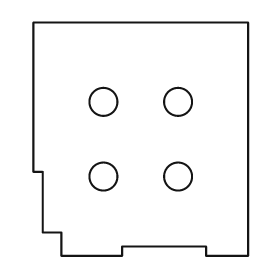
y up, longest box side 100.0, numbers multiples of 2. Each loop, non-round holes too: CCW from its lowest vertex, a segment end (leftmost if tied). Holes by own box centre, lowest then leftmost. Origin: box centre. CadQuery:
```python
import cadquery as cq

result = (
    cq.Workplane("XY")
    .moveTo(-34.0, -50.0)
    .lineTo(-8.0, -50.0)
    .lineTo(-8.0, -46.0)
    .lineTo(28.0, -46.0)
    .lineTo(28.0, -50.0)
    .lineTo(46.0, -50.0)
    .lineTo(46.0, 50.0)
    .lineTo(-46.0, 50.0)
    .lineTo(-46.0, -14.0)
    .lineTo(-42.0, -14.0)
    .lineTo(-42.0, -40.0)
    .lineTo(-34.0, -40.0)
    .close()
    .moveTo(-16.0, -16.0)
    .circle(6.0)
    .moveTo(16.0, -16.0)
    .circle(6.0)
    .moveTo(-16.0, 16.0)
    .circle(6.0)
    .moveTo(16.0, 16.0)
    .circle(6.0)
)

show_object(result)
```